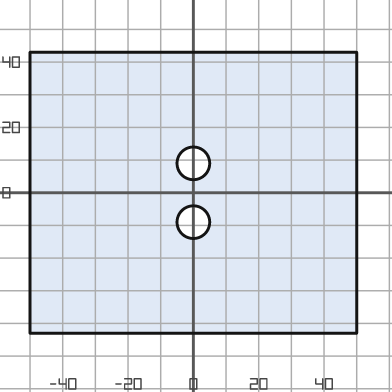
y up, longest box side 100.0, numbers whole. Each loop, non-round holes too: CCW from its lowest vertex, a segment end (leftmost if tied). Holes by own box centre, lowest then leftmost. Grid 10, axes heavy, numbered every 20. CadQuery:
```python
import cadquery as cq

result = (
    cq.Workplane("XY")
    .moveTo(-50.0, -43.0)
    .lineTo(50.0, -43.0)
    .lineTo(50.0, 43.0)
    .lineTo(-50.0, 43.0)
    .close()
    .moveTo(0.0, -9.0)
    .circle(5.0)
    .moveTo(0.0, 9.0)
    .circle(5.0)
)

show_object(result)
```